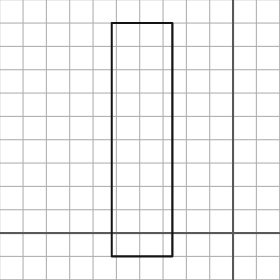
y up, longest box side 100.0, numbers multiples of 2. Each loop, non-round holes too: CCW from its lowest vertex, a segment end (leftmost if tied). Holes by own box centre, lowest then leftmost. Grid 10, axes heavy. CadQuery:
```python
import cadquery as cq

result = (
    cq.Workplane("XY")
    .moveTo(-52.0, -10.0)
    .lineTo(-26.0, -10.0)
    .lineTo(-26.0, 90.0)
    .lineTo(-52.0, 90.0)
    .close()
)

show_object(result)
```